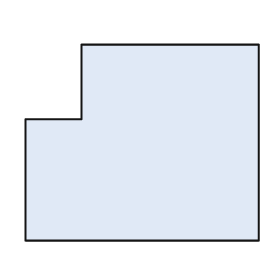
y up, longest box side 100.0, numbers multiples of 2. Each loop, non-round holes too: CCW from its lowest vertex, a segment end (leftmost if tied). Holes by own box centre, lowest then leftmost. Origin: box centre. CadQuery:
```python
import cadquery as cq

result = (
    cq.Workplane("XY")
    .moveTo(-50.0, -42.0)
    .lineTo(50.0, -42.0)
    .lineTo(50.0, 42.0)
    .lineTo(-26.0, 42.0)
    .lineTo(-26.0, 10.0)
    .lineTo(-50.0, 10.0)
    .close()
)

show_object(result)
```